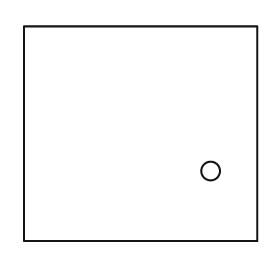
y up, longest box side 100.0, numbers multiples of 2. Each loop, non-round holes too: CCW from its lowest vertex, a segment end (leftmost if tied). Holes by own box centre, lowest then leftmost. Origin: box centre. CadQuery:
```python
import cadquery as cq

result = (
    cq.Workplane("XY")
    .moveTo(-50.0, -46.0)
    .lineTo(50.0, -46.0)
    .lineTo(50.0, 46.0)
    .lineTo(-50.0, 46.0)
    .close()
    .moveTo(30.0, -16.0)
    .circle(4.0)
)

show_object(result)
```